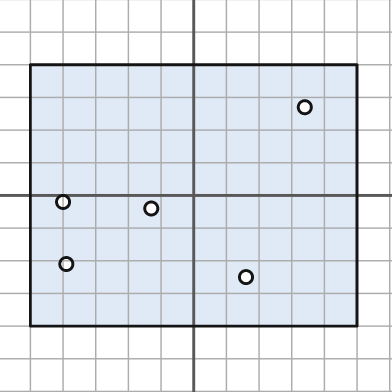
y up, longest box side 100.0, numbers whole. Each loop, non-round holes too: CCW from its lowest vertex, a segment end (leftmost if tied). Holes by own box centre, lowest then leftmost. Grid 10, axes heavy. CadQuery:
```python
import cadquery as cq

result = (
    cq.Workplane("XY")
    .moveTo(-50.0, -40.0)
    .lineTo(50.0, -40.0)
    .lineTo(50.0, 40.0)
    .lineTo(-50.0, 40.0)
    .close()
    .moveTo(16.0, -25.0)
    .circle(2.0)
    .moveTo(-39.0, -21.0)
    .circle(2.0)
    .moveTo(-13.0, -4.0)
    .circle(2.0)
    .moveTo(-40.0, -2.0)
    .circle(2.0)
    .moveTo(34.0, 27.0)
    .circle(2.0)
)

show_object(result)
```